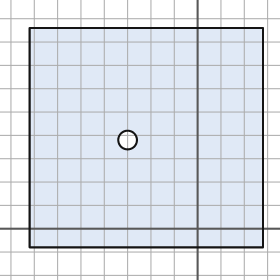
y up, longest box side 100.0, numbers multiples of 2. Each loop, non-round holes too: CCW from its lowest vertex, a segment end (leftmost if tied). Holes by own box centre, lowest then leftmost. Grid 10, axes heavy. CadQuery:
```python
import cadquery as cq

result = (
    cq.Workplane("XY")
    .moveTo(-72.0, -8.0)
    .lineTo(28.0, -8.0)
    .lineTo(28.0, 86.0)
    .lineTo(-72.0, 86.0)
    .close()
    .moveTo(-30.0, 38.0)
    .circle(4.0)
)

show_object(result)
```